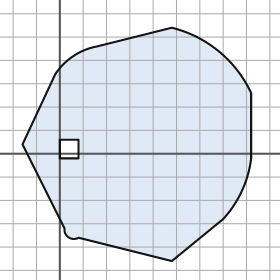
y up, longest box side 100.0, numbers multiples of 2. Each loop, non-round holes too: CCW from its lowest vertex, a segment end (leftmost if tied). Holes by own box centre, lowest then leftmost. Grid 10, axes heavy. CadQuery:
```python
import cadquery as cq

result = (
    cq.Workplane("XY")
    .moveTo(48.0, -46.0)
    .lineTo(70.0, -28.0)
    .threePointArc((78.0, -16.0), (82.0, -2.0))
    .lineTo(82.0, 26.0)
    .threePointArc((68.0, 44.0), (48.0, 54.0))
    .lineTo(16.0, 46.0)
    .threePointArc((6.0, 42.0), (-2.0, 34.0))
    .lineTo(-16.0, 4.0)
    .lineTo(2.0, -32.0)
    .threePointArc((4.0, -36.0), (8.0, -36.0))
    .close()
    .moveTo(0.0, -2.0)
    .lineTo(8.0, -2.0)
    .lineTo(8.0, 6.0)
    .lineTo(0.0, 6.0)
    .close()
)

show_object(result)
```